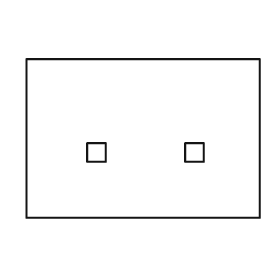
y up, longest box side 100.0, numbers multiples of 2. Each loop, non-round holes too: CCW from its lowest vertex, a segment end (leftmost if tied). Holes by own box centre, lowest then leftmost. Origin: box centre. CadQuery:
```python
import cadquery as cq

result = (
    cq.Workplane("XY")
    .moveTo(-50.0, -34.0)
    .lineTo(50.0, -34.0)
    .lineTo(50.0, 34.0)
    .lineTo(-50.0, 34.0)
    .close()
    .moveTo(-24.0, -10.0)
    .lineTo(-16.0, -10.0)
    .lineTo(-16.0, -2.0)
    .lineTo(-24.0, -2.0)
    .close()
    .moveTo(18.0, -10.0)
    .lineTo(26.0, -10.0)
    .lineTo(26.0, -2.0)
    .lineTo(18.0, -2.0)
    .close()
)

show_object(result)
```